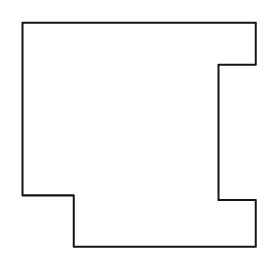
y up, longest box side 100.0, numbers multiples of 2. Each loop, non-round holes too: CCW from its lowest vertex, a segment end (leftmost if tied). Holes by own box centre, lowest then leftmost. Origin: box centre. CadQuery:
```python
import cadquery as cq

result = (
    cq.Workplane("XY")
    .moveTo(-28.0, -48.0)
    .lineTo(50.0, -48.0)
    .lineTo(50.0, -28.0)
    .lineTo(34.0, -28.0)
    .lineTo(34.0, 30.0)
    .lineTo(50.0, 30.0)
    .lineTo(50.0, 48.0)
    .lineTo(-50.0, 48.0)
    .lineTo(-50.0, -26.0)
    .lineTo(-28.0, -26.0)
    .close()
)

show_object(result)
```